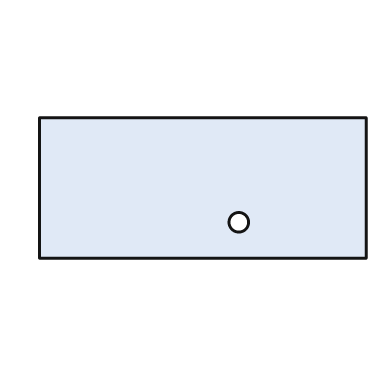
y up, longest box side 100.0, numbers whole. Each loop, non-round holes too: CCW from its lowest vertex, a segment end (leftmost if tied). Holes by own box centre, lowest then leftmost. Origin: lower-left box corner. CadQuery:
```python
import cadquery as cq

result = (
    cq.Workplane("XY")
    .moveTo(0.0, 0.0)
    .lineTo(100.0, 0.0)
    .lineTo(100.0, 43.0)
    .lineTo(0.0, 43.0)
    .close()
    .moveTo(61.0, 11.0)
    .circle(3.0)
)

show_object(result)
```